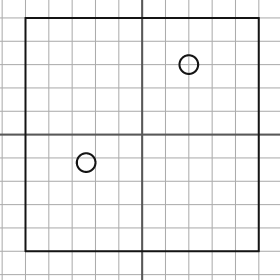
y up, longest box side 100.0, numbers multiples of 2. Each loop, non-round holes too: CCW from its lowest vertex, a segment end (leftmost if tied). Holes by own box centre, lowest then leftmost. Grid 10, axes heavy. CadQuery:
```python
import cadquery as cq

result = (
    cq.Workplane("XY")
    .moveTo(-50.0, -50.0)
    .lineTo(50.0, -50.0)
    .lineTo(50.0, 50.0)
    .lineTo(-50.0, 50.0)
    .close()
    .moveTo(-24.0, -12.0)
    .circle(4.0)
    .moveTo(20.0, 30.0)
    .circle(4.0)
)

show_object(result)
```